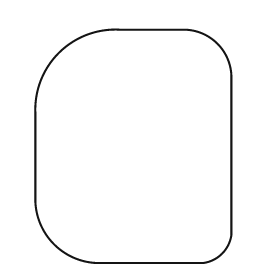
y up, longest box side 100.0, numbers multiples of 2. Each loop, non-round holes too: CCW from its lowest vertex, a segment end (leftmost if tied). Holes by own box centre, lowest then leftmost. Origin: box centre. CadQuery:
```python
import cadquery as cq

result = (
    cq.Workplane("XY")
    .moveTo(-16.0, -50.0)
    .lineTo(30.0, -50.0)
    .threePointArc((38.0, -46.0), (42.0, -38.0))
    .lineTo(42.0, 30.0)
    .threePointArc((36.0, 44.0), (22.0, 50.0))
    .lineTo(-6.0, 50.0)
    .threePointArc((-32.0, 40.0), (-42.0, 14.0))
    .lineTo(-42.0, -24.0)
    .threePointArc((-34.0, -42.0), (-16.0, -50.0))
    .close()
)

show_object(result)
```